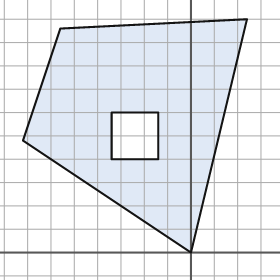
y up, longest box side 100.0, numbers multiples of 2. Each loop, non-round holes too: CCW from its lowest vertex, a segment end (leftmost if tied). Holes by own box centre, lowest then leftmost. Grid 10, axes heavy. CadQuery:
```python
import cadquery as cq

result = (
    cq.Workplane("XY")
    .moveTo(0.0, 0.0)
    .lineTo(24.0, 100.0)
    .lineTo(-56.0, 96.0)
    .lineTo(-72.0, 48.0)
    .close()
    .moveTo(-34.0, 40.0)
    .lineTo(-14.0, 40.0)
    .lineTo(-14.0, 60.0)
    .lineTo(-34.0, 60.0)
    .close()
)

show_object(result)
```